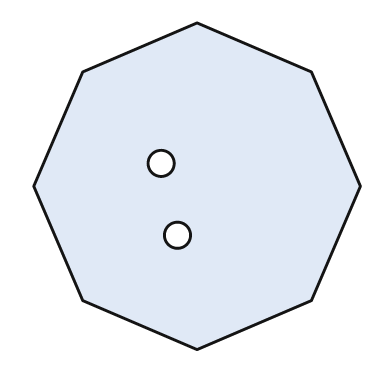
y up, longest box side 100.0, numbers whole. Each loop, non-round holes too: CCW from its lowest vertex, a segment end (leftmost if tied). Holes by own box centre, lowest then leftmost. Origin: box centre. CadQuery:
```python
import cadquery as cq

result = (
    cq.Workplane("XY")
    .moveTo(0.0, -50.0)
    .lineTo(35.0, -35.0)
    .lineTo(50.0, 0.0)
    .lineTo(35.0, 35.0)
    .lineTo(0.0, 50.0)
    .lineTo(-35.0, 35.0)
    .lineTo(-50.0, 0.0)
    .lineTo(-35.0, -35.0)
    .close()
    .moveTo(-6.0, -15.0)
    .circle(4.0)
    .moveTo(-11.0, 7.0)
    .circle(4.0)
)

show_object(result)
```